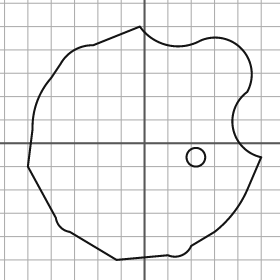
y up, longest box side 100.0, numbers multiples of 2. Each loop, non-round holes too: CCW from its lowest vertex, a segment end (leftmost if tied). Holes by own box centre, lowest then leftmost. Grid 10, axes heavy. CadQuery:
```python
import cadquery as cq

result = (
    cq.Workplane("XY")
    .moveTo(-12.0, -50.0)
    .lineTo(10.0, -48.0)
    .threePointArc((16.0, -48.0), (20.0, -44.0))
    .lineTo(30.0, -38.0)
    .threePointArc((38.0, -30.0), (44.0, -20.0))
    .lineTo(50.0, -6.0)
    .threePointArc((38.0, 6.0), (44.0, 22.0))
    .threePointArc((42.0, 40.0), (24.0, 44.0))
    .threePointArc((10.0, 42.0), (-2.0, 50.0))
    .lineTo(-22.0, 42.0)
    .threePointArc((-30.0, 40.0), (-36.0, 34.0))
    .lineTo(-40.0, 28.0)
    .threePointArc((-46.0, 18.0), (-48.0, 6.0))
    .lineTo(-50.0, -10.0)
    .lineTo(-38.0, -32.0)
    .threePointArc((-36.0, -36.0), (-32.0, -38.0))
    .close()
    .moveTo(22.0, -6.0)
    .circle(4.0)
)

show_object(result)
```